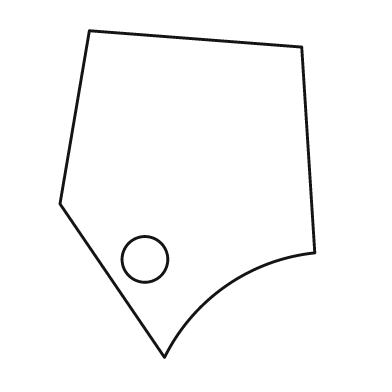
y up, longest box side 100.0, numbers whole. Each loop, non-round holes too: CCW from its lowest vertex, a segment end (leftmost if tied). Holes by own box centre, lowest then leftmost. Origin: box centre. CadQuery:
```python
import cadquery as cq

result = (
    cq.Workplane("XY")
    .moveTo(-7.0, -50.0)
    .threePointArc((12.0, -28.0), (39.0, -18.0))
    .lineTo(35.0, 45.0)
    .lineTo(-30.0, 50.0)
    .lineTo(-39.0, -3.0)
    .close()
    .moveTo(-13.0, -20.0)
    .circle(7.0)
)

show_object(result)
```